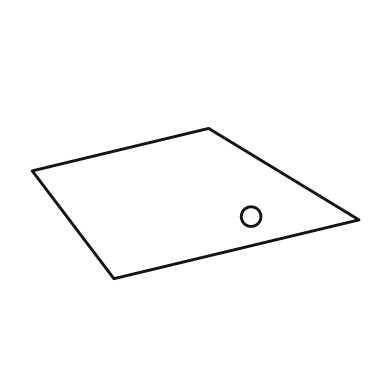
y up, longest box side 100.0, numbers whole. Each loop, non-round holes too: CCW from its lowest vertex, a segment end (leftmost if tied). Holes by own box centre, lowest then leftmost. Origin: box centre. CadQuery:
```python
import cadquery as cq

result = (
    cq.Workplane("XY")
    .moveTo(-25.0, -23.0)
    .lineTo(50.0, -5.0)
    .lineTo(4.0, 23.0)
    .lineTo(-50.0, 10.0)
    .close()
    .moveTo(17.0, -4.0)
    .circle(3.0)
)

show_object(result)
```